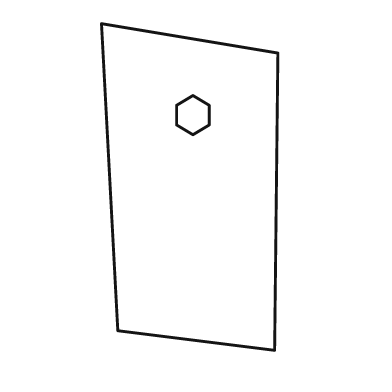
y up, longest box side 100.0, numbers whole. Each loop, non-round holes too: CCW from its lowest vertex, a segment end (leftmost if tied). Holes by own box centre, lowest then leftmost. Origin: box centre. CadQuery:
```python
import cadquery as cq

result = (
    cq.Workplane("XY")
    .moveTo(26.0, -50.0)
    .lineTo(27.0, 41.0)
    .lineTo(-27.0, 50.0)
    .lineTo(-22.0, -44.0)
    .close()
    .moveTo(1.0, 16.0)
    .lineTo(6.0, 19.0)
    .lineTo(6.0, 25.0)
    .lineTo(1.0, 28.0)
    .lineTo(-4.0, 25.0)
    .lineTo(-4.0, 19.0)
    .close()
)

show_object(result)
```